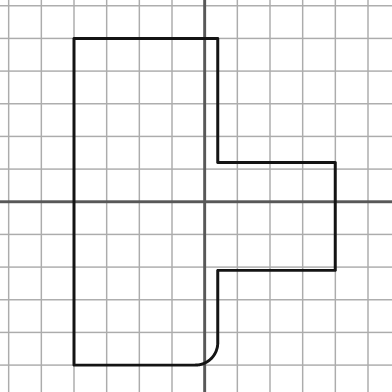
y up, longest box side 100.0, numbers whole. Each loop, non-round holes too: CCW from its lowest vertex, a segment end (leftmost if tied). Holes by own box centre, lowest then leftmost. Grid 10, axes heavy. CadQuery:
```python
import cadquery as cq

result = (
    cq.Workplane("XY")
    .moveTo(-40.0, -50.0)
    .lineTo(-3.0, -50.0)
    .threePointArc((2.0, -48.0), (4.0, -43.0))
    .lineTo(4.0, -21.0)
    .lineTo(40.0, -21.0)
    .lineTo(40.0, 12.0)
    .lineTo(4.0, 12.0)
    .lineTo(4.0, 50.0)
    .lineTo(-40.0, 50.0)
    .close()
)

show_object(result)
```